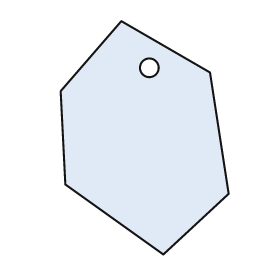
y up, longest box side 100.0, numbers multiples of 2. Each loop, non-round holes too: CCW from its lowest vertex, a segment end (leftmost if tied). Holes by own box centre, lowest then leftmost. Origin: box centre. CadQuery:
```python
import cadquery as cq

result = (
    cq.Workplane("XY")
    .moveTo(8.0, -50.0)
    .lineTo(36.0, -24.0)
    .lineTo(28.0, 28.0)
    .lineTo(-10.0, 50.0)
    .lineTo(-36.0, 20.0)
    .lineTo(-34.0, -20.0)
    .close()
    .moveTo(2.0, 30.0)
    .circle(4.0)
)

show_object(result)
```